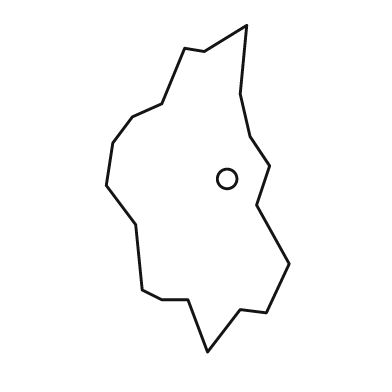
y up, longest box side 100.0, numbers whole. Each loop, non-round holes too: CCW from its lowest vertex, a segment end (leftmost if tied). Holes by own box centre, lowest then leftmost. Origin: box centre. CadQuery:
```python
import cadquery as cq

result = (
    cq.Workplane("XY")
    .moveTo(3.0, -50.0)
    .lineTo(13.0, -37.0)
    .lineTo(21.0, -38.0)
    .lineTo(28.0, -23.0)
    .lineTo(18.0, -5.0)
    .lineTo(22.0, 7.0)
    .lineTo(16.0, 16.0)
    .lineTo(13.0, 29.0)
    .lineTo(15.0, 50.0)
    .lineTo(2.0, 42.0)
    .lineTo(-4.0, 43.0)
    .lineTo(-11.0, 26.0)
    .lineTo(-20.0, 22.0)
    .lineTo(-26.0, 14.0)
    .lineTo(-28.0, 1.0)
    .lineTo(-19.0, -11.0)
    .lineTo(-17.0, -31.0)
    .lineTo(-11.0, -34.0)
    .lineTo(-3.0, -34.0)
    .close()
    .moveTo(9.0, 3.0)
    .circle(3.0)
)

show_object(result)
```